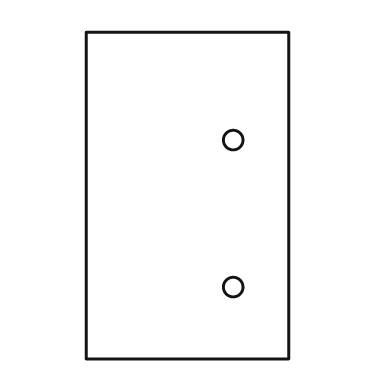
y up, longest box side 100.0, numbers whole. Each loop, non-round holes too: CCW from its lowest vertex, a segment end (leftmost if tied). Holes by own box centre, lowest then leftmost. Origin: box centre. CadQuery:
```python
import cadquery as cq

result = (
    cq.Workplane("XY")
    .moveTo(-31.0, -50.0)
    .lineTo(31.0, -50.0)
    .lineTo(31.0, 50.0)
    .lineTo(-31.0, 50.0)
    .close()
    .moveTo(14.0, -28.0)
    .circle(3.0)
    .moveTo(14.0, 17.0)
    .circle(3.0)
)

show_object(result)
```